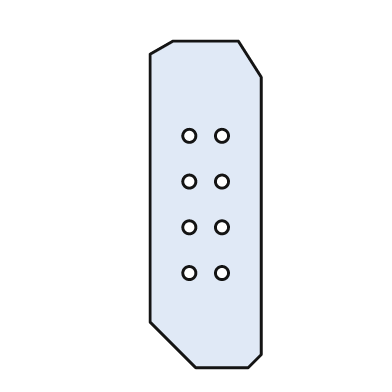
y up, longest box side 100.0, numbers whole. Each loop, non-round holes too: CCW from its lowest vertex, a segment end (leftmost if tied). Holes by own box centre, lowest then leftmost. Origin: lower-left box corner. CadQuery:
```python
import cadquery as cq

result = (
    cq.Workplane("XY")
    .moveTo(14.0, 0.0)
    .lineTo(30.0, 0.0)
    .lineTo(34.0, 4.0)
    .lineTo(34.0, 89.0)
    .lineTo(27.0, 100.0)
    .lineTo(7.0, 100.0)
    .lineTo(0.0, 96.0)
    .lineTo(0.0, 14.0)
    .close()
    .moveTo(12.0, 29.0)
    .circle(2.0)
    .moveTo(22.0, 29.0)
    .circle(2.0)
    .moveTo(12.0, 43.0)
    .circle(2.0)
    .moveTo(22.0, 43.0)
    .circle(2.0)
    .moveTo(12.0, 57.0)
    .circle(2.0)
    .moveTo(22.0, 57.0)
    .circle(2.0)
    .moveTo(12.0, 71.0)
    .circle(2.0)
    .moveTo(22.0, 71.0)
    .circle(2.0)
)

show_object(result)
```